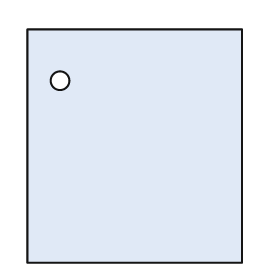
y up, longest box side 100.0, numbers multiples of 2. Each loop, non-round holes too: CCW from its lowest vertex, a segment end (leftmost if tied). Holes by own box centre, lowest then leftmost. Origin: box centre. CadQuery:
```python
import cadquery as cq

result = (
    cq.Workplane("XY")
    .moveTo(-46.0, -50.0)
    .lineTo(46.0, -50.0)
    .lineTo(46.0, 50.0)
    .lineTo(-46.0, 50.0)
    .close()
    .moveTo(-32.0, 28.0)
    .circle(4.0)
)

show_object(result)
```